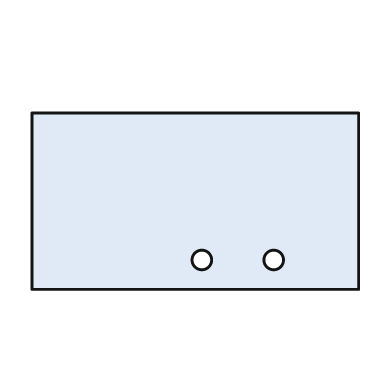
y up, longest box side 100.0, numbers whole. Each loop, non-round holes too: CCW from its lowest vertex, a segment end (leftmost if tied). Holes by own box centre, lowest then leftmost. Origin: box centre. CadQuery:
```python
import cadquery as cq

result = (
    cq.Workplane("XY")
    .moveTo(-50.0, -27.0)
    .lineTo(50.0, -27.0)
    .lineTo(50.0, 27.0)
    .lineTo(-50.0, 27.0)
    .close()
    .moveTo(2.0, -18.0)
    .circle(3.0)
    .moveTo(24.0, -18.0)
    .circle(3.0)
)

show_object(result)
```